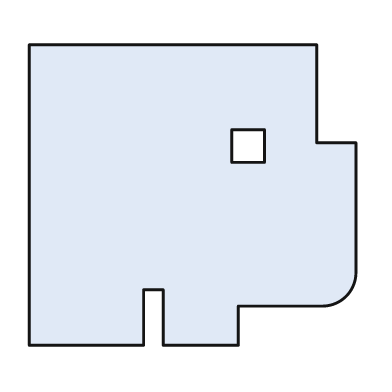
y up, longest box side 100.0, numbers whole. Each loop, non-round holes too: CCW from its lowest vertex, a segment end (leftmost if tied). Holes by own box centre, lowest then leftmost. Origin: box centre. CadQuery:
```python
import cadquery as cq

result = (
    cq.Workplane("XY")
    .moveTo(-50.0, -46.0)
    .lineTo(-15.0, -46.0)
    .lineTo(-15.0, -29.0)
    .lineTo(-9.0, -29.0)
    .lineTo(-9.0, -46.0)
    .lineTo(14.0, -46.0)
    .lineTo(14.0, -34.0)
    .lineTo(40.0, -34.0)
    .threePointArc((47.0, -31.0), (50.0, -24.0))
    .lineTo(50.0, 16.0)
    .lineTo(38.0, 16.0)
    .lineTo(38.0, 46.0)
    .lineTo(-50.0, 46.0)
    .close()
    .moveTo(12.0, 10.0)
    .lineTo(22.0, 10.0)
    .lineTo(22.0, 20.0)
    .lineTo(12.0, 20.0)
    .close()
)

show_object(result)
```